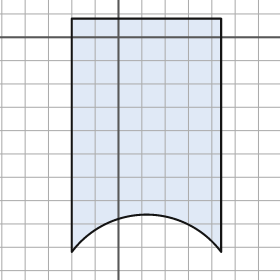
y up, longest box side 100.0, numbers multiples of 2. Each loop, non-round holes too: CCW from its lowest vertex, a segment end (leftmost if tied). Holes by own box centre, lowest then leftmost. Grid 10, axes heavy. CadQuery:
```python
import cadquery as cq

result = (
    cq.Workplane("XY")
    .moveTo(-20.0, -92.0)
    .threePointArc((12.0, -76.0), (44.0, -92.0))
    .lineTo(44.0, 8.0)
    .lineTo(-20.0, 8.0)
    .close()
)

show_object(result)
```